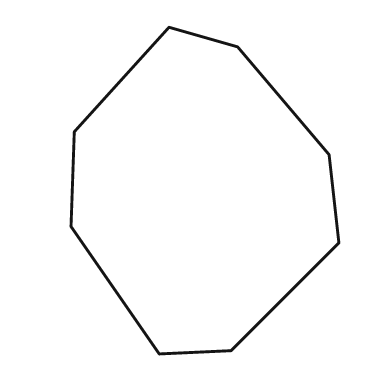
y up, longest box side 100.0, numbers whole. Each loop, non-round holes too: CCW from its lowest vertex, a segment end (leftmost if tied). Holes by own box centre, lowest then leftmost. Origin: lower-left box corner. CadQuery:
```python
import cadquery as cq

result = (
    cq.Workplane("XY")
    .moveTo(27.0, 0.0)
    .lineTo(49.0, 1.0)
    .lineTo(82.0, 34.0)
    .lineTo(79.0, 61.0)
    .lineTo(51.0, 94.0)
    .lineTo(30.0, 100.0)
    .lineTo(1.0, 68.0)
    .lineTo(0.0, 39.0)
    .close()
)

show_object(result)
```